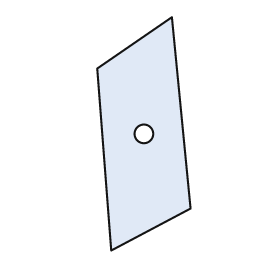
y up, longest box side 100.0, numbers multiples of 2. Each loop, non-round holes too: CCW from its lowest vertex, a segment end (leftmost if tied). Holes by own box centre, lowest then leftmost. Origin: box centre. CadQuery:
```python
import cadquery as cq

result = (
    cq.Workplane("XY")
    .moveTo(-14.0, -50.0)
    .lineTo(20.0, -32.0)
    .lineTo(12.0, 50.0)
    .lineTo(-20.0, 28.0)
    .close()
    .moveTo(0.0, 0.0)
    .circle(4.0)
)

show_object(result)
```